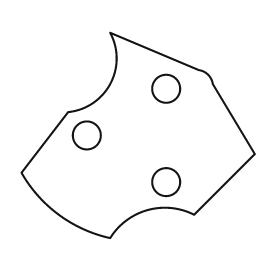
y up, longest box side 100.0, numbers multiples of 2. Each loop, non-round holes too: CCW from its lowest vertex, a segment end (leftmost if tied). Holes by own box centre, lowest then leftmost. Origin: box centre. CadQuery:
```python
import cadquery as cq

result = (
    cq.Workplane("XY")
    .moveTo(-12.0, -44.0)
    .threePointArc((4.0, -32.0), (24.0, -34.0))
    .lineTo(50.0, -8.0)
    .lineTo(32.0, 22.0)
    .threePointArc((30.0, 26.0), (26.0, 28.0))
    .lineTo(-12.0, 44.0)
    .threePointArc((-12.0, 22.0), (-30.0, 10.0))
    .lineTo(-50.0, -16.0)
    .threePointArc((-34.0, -34.0), (-12.0, -44.0))
    .close()
    .moveTo(12.0, -20.0)
    .circle(6.0)
    .moveTo(-22.0, 0.0)
    .circle(6.0)
    .moveTo(12.0, 20.0)
    .circle(6.0)
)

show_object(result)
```